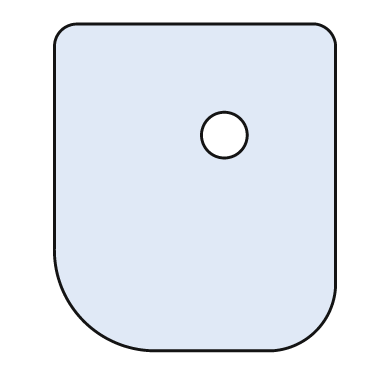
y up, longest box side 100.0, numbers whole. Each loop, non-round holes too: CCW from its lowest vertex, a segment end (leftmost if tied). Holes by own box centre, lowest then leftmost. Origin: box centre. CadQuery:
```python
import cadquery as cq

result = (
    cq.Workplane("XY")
    .moveTo(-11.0, -50.0)
    .lineTo(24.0, -50.0)
    .threePointArc((37.0, -44.0), (43.0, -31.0))
    .lineTo(43.0, 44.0)
    .threePointArc((41.0, 48.0), (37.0, 50.0))
    .lineTo(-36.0, 50.0)
    .threePointArc((-41.0, 48.0), (-43.0, 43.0))
    .lineTo(-43.0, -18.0)
    .threePointArc((-34.0, -41.0), (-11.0, -50.0))
    .close()
    .moveTo(9.0, 16.0)
    .circle(7.0)
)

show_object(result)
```